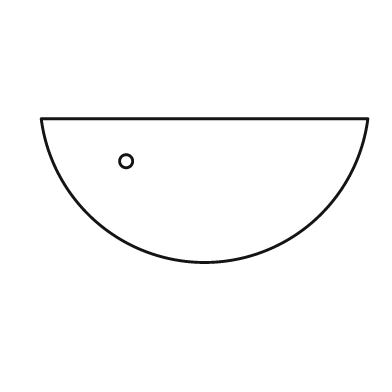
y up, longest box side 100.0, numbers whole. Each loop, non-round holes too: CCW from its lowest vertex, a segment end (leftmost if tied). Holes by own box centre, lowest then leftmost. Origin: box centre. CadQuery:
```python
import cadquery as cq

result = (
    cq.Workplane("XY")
    .moveTo(-50.0, 22.0)
    .threePointArc((0.0, -22.0), (50.0, 22.0))
    .close()
    .moveTo(-24.0, 9.0)
    .circle(2.0)
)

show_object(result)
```